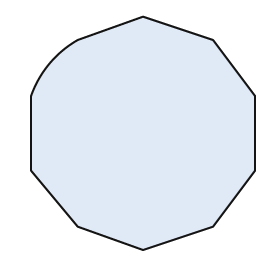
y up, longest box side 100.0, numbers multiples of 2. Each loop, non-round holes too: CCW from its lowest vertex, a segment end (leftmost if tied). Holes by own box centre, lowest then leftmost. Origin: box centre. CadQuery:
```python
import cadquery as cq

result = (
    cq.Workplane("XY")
    .moveTo(0.0, -50.0)
    .lineTo(30.0, -40.0)
    .lineTo(48.0, -16.0)
    .lineTo(48.0, 16.0)
    .lineTo(30.0, 40.0)
    .lineTo(0.0, 50.0)
    .lineTo(-28.0, 40.0)
    .threePointArc((-40.0, 30.0), (-48.0, 16.0))
    .lineTo(-48.0, -16.0)
    .lineTo(-28.0, -40.0)
    .close()
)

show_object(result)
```